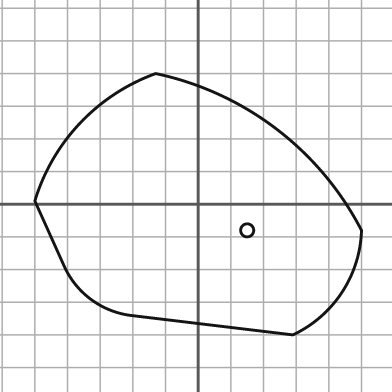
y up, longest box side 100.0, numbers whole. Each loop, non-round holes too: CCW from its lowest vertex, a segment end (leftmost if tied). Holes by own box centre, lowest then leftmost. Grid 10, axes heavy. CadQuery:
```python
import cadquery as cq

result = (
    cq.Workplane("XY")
    .moveTo(29.0, -40.0)
    .threePointArc((44.0, -27.0), (50.0, -8.0))
    .threePointArc((24.0, 23.0), (-13.0, 40.0))
    .threePointArc((-36.0, 25.0), (-50.0, 1.0))
    .lineTo(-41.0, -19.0)
    .threePointArc((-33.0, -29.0), (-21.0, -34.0))
    .close()
    .moveTo(15.0, -8.0)
    .circle(2.0)
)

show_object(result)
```